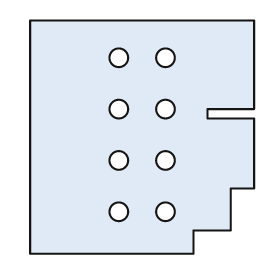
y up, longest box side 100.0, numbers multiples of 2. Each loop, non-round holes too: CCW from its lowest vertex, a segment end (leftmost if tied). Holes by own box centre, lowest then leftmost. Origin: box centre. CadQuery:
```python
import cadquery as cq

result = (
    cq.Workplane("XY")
    .moveTo(-48.0, -50.0)
    .lineTo(22.0, -50.0)
    .lineTo(22.0, -40.0)
    .lineTo(38.0, -40.0)
    .lineTo(38.0, -22.0)
    .lineTo(48.0, -22.0)
    .lineTo(48.0, 8.0)
    .lineTo(28.0, 8.0)
    .lineTo(28.0, 12.0)
    .lineTo(48.0, 12.0)
    .lineTo(48.0, 50.0)
    .lineTo(-48.0, 50.0)
    .close()
    .moveTo(-10.0, -32.0)
    .circle(4.0)
    .moveTo(10.0, -32.0)
    .circle(4.0)
    .moveTo(-10.0, -10.0)
    .circle(4.0)
    .moveTo(10.0, -10.0)
    .circle(4.0)
    .moveTo(-10.0, 12.0)
    .circle(4.0)
    .moveTo(10.0, 12.0)
    .circle(4.0)
    .moveTo(-10.0, 34.0)
    .circle(4.0)
    .moveTo(10.0, 34.0)
    .circle(4.0)
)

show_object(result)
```